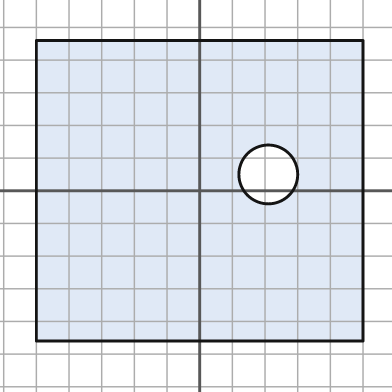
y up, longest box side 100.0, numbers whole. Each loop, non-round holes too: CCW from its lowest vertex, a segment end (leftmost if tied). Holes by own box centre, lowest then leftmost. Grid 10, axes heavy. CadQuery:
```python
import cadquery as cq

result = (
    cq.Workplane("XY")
    .moveTo(-50.0, -46.0)
    .lineTo(50.0, -46.0)
    .lineTo(50.0, 46.0)
    .lineTo(-50.0, 46.0)
    .close()
    .moveTo(21.0, 5.0)
    .circle(9.0)
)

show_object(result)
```